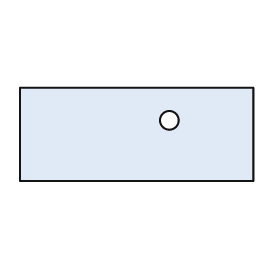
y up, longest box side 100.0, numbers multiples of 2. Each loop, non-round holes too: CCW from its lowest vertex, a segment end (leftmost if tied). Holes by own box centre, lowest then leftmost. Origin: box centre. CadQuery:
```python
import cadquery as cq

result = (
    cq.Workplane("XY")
    .moveTo(-50.0, -20.0)
    .lineTo(50.0, -20.0)
    .lineTo(50.0, 20.0)
    .lineTo(-50.0, 20.0)
    .close()
    .moveTo(14.0, 6.0)
    .circle(4.0)
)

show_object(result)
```